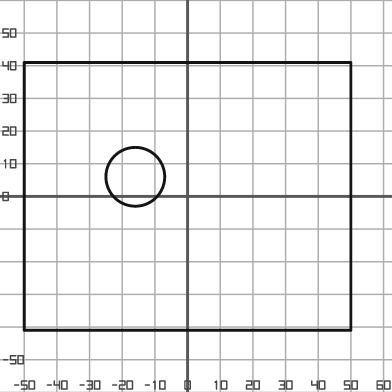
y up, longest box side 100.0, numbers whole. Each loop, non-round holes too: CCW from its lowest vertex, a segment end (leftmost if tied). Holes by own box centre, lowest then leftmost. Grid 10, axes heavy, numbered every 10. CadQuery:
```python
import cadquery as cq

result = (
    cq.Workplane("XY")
    .moveTo(-50.0, -41.0)
    .lineTo(50.0, -41.0)
    .lineTo(50.0, 41.0)
    .lineTo(-50.0, 41.0)
    .close()
    .moveTo(-16.0, 6.0)
    .circle(9.0)
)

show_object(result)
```